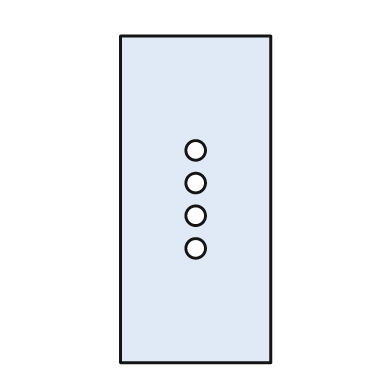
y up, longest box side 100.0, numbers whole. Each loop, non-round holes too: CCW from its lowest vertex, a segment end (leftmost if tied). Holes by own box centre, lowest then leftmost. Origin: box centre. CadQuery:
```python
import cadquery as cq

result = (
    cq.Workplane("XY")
    .moveTo(-23.0, -50.0)
    .lineTo(23.0, -50.0)
    .lineTo(23.0, 50.0)
    .lineTo(-23.0, 50.0)
    .close()
    .moveTo(0.0, -15.0)
    .circle(3.0)
    .moveTo(0.0, -5.0)
    .circle(3.0)
    .moveTo(0.0, 5.0)
    .circle(3.0)
    .moveTo(0.0, 15.0)
    .circle(3.0)
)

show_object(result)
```